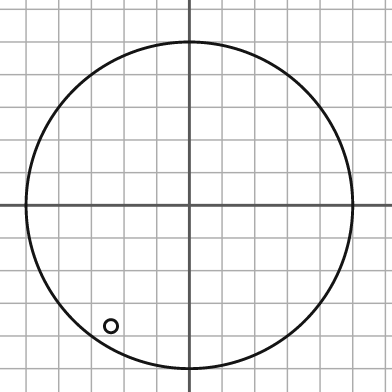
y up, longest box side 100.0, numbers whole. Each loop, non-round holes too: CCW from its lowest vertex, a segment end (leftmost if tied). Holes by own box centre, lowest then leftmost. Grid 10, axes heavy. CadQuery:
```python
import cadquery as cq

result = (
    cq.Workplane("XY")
    .moveTo(0.0, 0.0)
    .circle(50.0)
    .moveTo(-24.0, -37.0)
    .circle(2.0)
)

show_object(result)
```